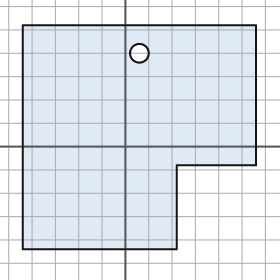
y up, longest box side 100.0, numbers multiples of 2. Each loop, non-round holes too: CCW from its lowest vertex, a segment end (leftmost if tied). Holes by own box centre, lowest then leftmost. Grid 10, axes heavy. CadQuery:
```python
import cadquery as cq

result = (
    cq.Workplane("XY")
    .moveTo(-44.0, -44.0)
    .lineTo(22.0, -44.0)
    .lineTo(22.0, -8.0)
    .lineTo(56.0, -8.0)
    .lineTo(56.0, 52.0)
    .lineTo(-44.0, 52.0)
    .close()
    .moveTo(6.0, 40.0)
    .circle(4.0)
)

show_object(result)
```